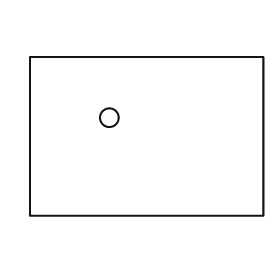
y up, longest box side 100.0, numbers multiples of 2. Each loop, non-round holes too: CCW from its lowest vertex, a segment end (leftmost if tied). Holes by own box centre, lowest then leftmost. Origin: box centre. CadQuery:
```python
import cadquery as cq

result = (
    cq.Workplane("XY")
    .moveTo(-50.0, -34.0)
    .lineTo(50.0, -34.0)
    .lineTo(50.0, 34.0)
    .lineTo(-50.0, 34.0)
    .close()
    .moveTo(-16.0, 8.0)
    .circle(4.0)
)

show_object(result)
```